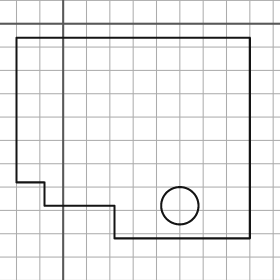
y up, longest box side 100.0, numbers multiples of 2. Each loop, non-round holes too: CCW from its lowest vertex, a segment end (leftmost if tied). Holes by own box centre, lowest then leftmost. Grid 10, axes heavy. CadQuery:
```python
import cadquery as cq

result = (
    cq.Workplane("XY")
    .moveTo(22.0, -92.0)
    .lineTo(80.0, -92.0)
    .lineTo(80.0, -6.0)
    .lineTo(-20.0, -6.0)
    .lineTo(-20.0, -68.0)
    .lineTo(-8.0, -68.0)
    .lineTo(-8.0, -78.0)
    .lineTo(22.0, -78.0)
    .close()
    .moveTo(50.0, -78.0)
    .circle(8.0)
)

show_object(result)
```